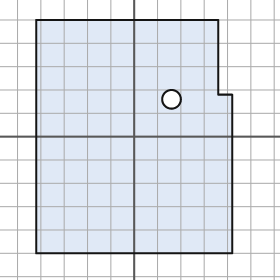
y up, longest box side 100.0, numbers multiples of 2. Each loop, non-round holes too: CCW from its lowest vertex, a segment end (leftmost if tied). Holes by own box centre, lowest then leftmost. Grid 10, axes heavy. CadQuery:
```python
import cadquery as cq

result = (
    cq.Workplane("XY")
    .moveTo(-42.0, -50.0)
    .lineTo(42.0, -50.0)
    .lineTo(42.0, 18.0)
    .lineTo(36.0, 18.0)
    .lineTo(36.0, 50.0)
    .lineTo(-42.0, 50.0)
    .close()
    .moveTo(16.0, 16.0)
    .circle(4.0)
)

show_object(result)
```